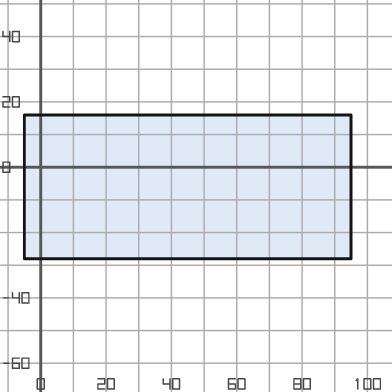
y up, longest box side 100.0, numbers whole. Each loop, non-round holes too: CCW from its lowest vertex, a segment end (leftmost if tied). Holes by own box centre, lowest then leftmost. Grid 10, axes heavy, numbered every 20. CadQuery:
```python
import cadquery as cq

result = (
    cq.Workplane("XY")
    .moveTo(-5.0, -28.0)
    .lineTo(95.0, -28.0)
    .lineTo(95.0, 16.0)
    .lineTo(-5.0, 16.0)
    .close()
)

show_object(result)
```